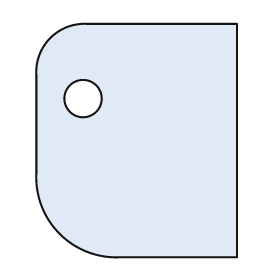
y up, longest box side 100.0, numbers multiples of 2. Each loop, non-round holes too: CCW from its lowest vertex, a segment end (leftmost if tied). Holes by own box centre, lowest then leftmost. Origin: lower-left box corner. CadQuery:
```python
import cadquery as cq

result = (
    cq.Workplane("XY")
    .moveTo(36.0, 0.0)
    .lineTo(86.0, 0.0)
    .lineTo(86.0, 100.0)
    .lineTo(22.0, 100.0)
    .threePointArc((6.0, 94.0), (0.0, 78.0))
    .lineTo(0.0, 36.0)
    .threePointArc((10.0, 10.0), (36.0, 0.0))
    .close()
    .moveTo(20.0, 68.0)
    .circle(8.0)
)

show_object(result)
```